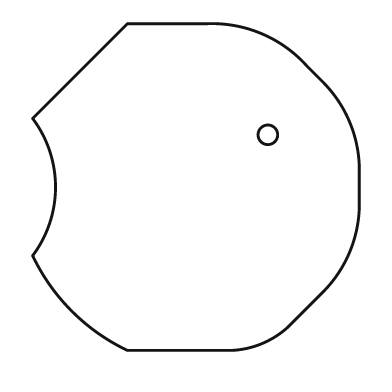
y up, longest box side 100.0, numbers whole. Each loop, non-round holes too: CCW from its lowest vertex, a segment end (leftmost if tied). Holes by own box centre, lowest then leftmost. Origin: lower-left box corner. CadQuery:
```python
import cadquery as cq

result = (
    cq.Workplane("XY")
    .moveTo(29.0, 0.0)
    .lineTo(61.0, 0.0)
    .threePointArc((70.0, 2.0), (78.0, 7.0))
    .lineTo(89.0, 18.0)
    .threePointArc((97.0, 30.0), (100.0, 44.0))
    .lineTo(100.0, 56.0)
    .threePointArc((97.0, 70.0), (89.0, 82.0))
    .lineTo(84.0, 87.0)
    .threePointArc((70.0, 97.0), (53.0, 100.0))
    .lineTo(29.0, 100.0)
    .lineTo(0.0, 71.0)
    .threePointArc((7.0, 50.0), (0.0, 29.0))
    .threePointArc((12.0, 12.0), (29.0, 0.0))
    .close()
    .moveTo(72.0, 66.0)
    .circle(3.0)
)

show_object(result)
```